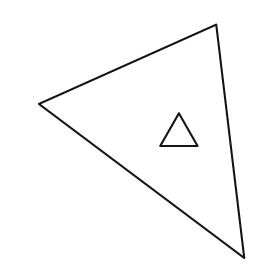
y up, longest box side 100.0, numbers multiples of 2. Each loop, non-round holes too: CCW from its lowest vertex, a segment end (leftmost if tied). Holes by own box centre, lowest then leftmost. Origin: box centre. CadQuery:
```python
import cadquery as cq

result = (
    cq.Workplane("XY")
    .moveTo(44.0, -50.0)
    .lineTo(32.0, 50.0)
    .lineTo(-44.0, 16.0)
    .close()
    .moveTo(8.0, -2.0)
    .lineTo(24.0, -2.0)
    .lineTo(16.0, 12.0)
    .close()
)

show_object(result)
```